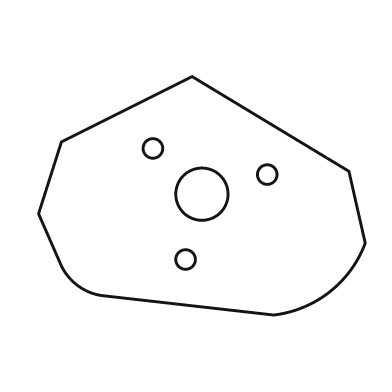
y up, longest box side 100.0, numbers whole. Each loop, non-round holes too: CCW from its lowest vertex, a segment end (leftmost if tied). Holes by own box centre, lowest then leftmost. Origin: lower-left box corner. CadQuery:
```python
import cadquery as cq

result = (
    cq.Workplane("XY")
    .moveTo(72.0, 0.0)
    .threePointArc((89.0, 7.0), (100.0, 22.0))
    .lineTo(95.0, 44.0)
    .lineTo(47.0, 73.0)
    .lineTo(7.0, 53.0)
    .lineTo(0.0, 31.0)
    .lineTo(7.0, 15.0)
    .threePointArc((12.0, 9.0), (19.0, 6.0))
    .close()
    .moveTo(45.0, 17.0)
    .circle(3.0)
    .moveTo(50.0, 37.0)
    .circle(8.0)
    .moveTo(70.0, 43.0)
    .circle(3.0)
    .moveTo(35.0, 51.0)
    .circle(3.0)
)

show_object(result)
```